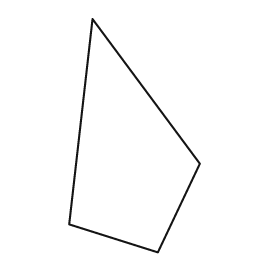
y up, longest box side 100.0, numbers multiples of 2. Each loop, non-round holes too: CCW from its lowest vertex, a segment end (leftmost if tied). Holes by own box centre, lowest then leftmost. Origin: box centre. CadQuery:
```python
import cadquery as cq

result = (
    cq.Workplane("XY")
    .moveTo(10.0, -50.0)
    .lineTo(28.0, -12.0)
    .lineTo(-18.0, 50.0)
    .lineTo(-28.0, -38.0)
    .close()
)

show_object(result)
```